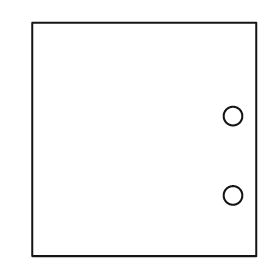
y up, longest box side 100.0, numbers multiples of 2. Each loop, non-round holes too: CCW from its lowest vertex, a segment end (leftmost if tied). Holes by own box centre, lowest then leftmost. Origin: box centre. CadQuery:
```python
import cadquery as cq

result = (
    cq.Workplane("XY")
    .moveTo(-48.0, -50.0)
    .lineTo(48.0, -50.0)
    .lineTo(48.0, 50.0)
    .lineTo(-48.0, 50.0)
    .close()
    .moveTo(38.0, -24.0)
    .circle(4.0)
    .moveTo(38.0, 10.0)
    .circle(4.0)
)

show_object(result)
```